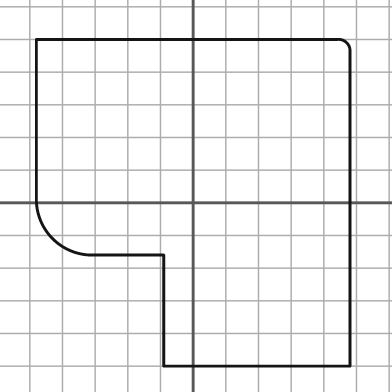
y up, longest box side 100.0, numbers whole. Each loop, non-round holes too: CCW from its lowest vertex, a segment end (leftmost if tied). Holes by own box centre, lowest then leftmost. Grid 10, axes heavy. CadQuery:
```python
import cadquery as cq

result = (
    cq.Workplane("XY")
    .moveTo(-9.0, -50.0)
    .lineTo(48.0, -50.0)
    .lineTo(48.0, 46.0)
    .threePointArc((47.0, 49.0), (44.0, 50.0))
    .lineTo(-48.0, 50.0)
    .lineTo(-48.0, 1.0)
    .threePointArc((-43.0, -11.0), (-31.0, -16.0))
    .lineTo(-9.0, -16.0)
    .close()
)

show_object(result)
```